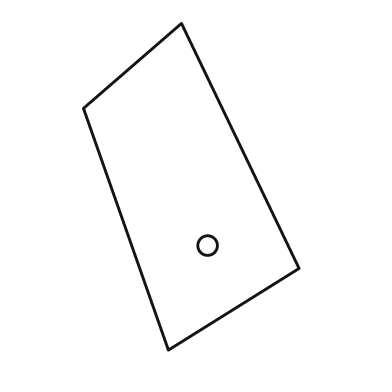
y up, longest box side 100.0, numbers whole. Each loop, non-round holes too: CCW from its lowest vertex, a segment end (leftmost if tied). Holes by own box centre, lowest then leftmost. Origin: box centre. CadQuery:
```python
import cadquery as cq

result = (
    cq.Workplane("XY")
    .moveTo(-7.0, -50.0)
    .lineTo(33.0, -25.0)
    .lineTo(-3.0, 50.0)
    .lineTo(-33.0, 24.0)
    .close()
    .moveTo(5.0, -18.0)
    .circle(3.0)
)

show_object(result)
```